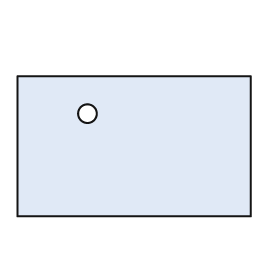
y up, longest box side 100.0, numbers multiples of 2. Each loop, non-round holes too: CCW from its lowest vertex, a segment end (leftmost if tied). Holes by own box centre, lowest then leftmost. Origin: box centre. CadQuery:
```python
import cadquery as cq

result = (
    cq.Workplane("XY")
    .moveTo(-50.0, -30.0)
    .lineTo(50.0, -30.0)
    .lineTo(50.0, 30.0)
    .lineTo(-50.0, 30.0)
    .close()
    .moveTo(-20.0, 14.0)
    .circle(4.0)
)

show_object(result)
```